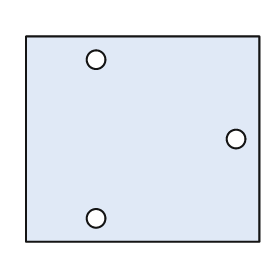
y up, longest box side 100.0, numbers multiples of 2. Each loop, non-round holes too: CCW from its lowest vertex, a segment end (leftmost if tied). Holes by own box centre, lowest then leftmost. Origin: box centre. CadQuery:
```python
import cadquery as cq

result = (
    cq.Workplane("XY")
    .moveTo(-50.0, -44.0)
    .lineTo(50.0, -44.0)
    .lineTo(50.0, 44.0)
    .lineTo(-50.0, 44.0)
    .close()
    .moveTo(-20.0, -34.0)
    .circle(4.0)
    .moveTo(40.0, 0.0)
    .circle(4.0)
    .moveTo(-20.0, 34.0)
    .circle(4.0)
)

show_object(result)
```